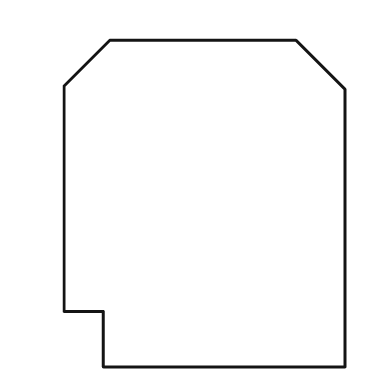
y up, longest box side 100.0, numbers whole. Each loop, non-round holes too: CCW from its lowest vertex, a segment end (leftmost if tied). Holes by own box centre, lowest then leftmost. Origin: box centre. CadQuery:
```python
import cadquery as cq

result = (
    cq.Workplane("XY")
    .moveTo(-31.0, -50.0)
    .lineTo(43.0, -50.0)
    .lineTo(43.0, 35.0)
    .lineTo(28.0, 50.0)
    .lineTo(-29.0, 50.0)
    .lineTo(-43.0, 36.0)
    .lineTo(-43.0, -33.0)
    .lineTo(-31.0, -33.0)
    .close()
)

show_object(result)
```